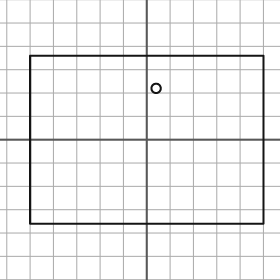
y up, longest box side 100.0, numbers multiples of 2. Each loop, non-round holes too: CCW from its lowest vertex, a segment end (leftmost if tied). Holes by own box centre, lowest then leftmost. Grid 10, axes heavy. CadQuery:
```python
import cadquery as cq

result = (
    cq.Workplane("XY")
    .moveTo(-50.0, -36.0)
    .lineTo(50.0, -36.0)
    .lineTo(50.0, 36.0)
    .lineTo(-50.0, 36.0)
    .close()
    .moveTo(4.0, 22.0)
    .circle(2.0)
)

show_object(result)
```